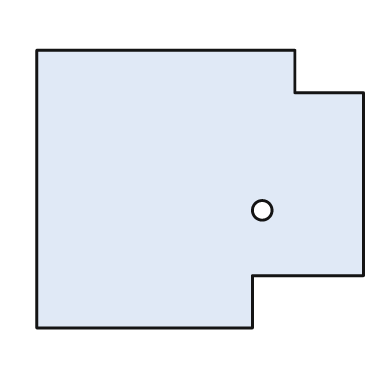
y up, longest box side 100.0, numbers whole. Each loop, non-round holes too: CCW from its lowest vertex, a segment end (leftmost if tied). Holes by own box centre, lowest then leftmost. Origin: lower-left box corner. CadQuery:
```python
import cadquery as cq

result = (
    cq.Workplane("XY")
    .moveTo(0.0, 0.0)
    .lineTo(66.0, 0.0)
    .lineTo(66.0, 16.0)
    .lineTo(100.0, 16.0)
    .lineTo(100.0, 72.0)
    .lineTo(79.0, 72.0)
    .lineTo(79.0, 85.0)
    .lineTo(0.0, 85.0)
    .close()
    .moveTo(69.0, 36.0)
    .circle(3.0)
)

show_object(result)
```